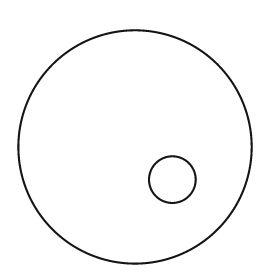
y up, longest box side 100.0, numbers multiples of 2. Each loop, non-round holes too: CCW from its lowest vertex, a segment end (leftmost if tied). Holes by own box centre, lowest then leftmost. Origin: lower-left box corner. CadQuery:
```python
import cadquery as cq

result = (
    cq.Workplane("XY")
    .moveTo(50.0, 50.0)
    .circle(50.0)
    .moveTo(66.0, 36.0)
    .circle(10.0)
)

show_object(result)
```